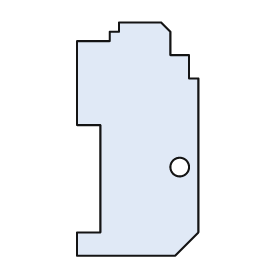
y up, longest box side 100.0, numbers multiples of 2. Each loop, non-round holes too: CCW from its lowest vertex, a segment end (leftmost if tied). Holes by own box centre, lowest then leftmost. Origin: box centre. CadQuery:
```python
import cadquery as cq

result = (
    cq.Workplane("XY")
    .moveTo(-26.0, -50.0)
    .lineTo(16.0, -50.0)
    .lineTo(26.0, -40.0)
    .lineTo(26.0, 26.0)
    .lineTo(22.0, 26.0)
    .lineTo(22.0, 36.0)
    .lineTo(14.0, 36.0)
    .lineTo(14.0, 46.0)
    .lineTo(10.0, 50.0)
    .lineTo(-8.0, 50.0)
    .lineTo(-8.0, 46.0)
    .lineTo(-12.0, 46.0)
    .lineTo(-12.0, 42.0)
    .lineTo(-26.0, 42.0)
    .lineTo(-26.0, 6.0)
    .lineTo(-16.0, 6.0)
    .lineTo(-16.0, -40.0)
    .lineTo(-26.0, -40.0)
    .close()
    .moveTo(18.0, -12.0)
    .circle(4.0)
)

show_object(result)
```